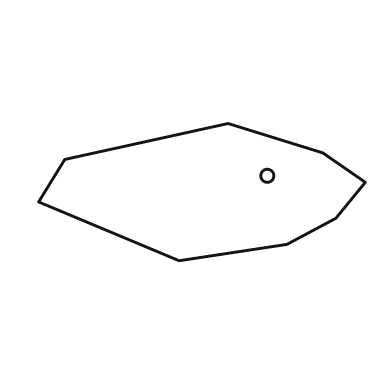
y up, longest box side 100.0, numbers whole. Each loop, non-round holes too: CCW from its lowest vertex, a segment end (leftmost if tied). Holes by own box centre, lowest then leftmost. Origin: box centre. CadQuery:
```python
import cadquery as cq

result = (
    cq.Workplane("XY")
    .moveTo(-7.0, -21.0)
    .lineTo(26.0, -16.0)
    .lineTo(41.0, -8.0)
    .lineTo(50.0, 3.0)
    .lineTo(37.0, 12.0)
    .lineTo(8.0, 21.0)
    .lineTo(-42.0, 10.0)
    .lineTo(-50.0, -3.0)
    .close()
    .moveTo(20.0, 5.0)
    .circle(2.0)
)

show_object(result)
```